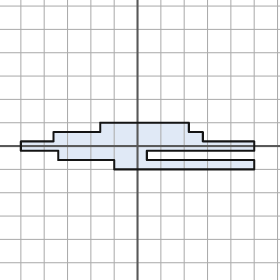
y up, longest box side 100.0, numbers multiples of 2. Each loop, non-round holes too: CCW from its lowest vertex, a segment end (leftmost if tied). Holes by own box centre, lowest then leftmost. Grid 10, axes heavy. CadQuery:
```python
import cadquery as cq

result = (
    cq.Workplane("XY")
    .moveTo(-10.0, -10.0)
    .lineTo(50.0, -10.0)
    .lineTo(50.0, -6.0)
    .lineTo(4.0, -6.0)
    .lineTo(4.0, -2.0)
    .lineTo(50.0, -2.0)
    .lineTo(50.0, 2.0)
    .lineTo(28.0, 2.0)
    .lineTo(28.0, 6.0)
    .lineTo(22.0, 6.0)
    .lineTo(22.0, 10.0)
    .lineTo(-16.0, 10.0)
    .lineTo(-16.0, 6.0)
    .lineTo(-36.0, 6.0)
    .lineTo(-36.0, 2.0)
    .lineTo(-50.0, 2.0)
    .lineTo(-50.0, -2.0)
    .lineTo(-34.0, -2.0)
    .lineTo(-34.0, -6.0)
    .lineTo(-10.0, -6.0)
    .close()
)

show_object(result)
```